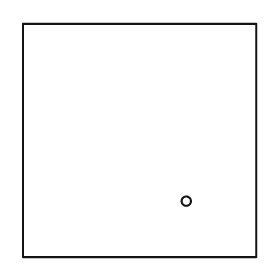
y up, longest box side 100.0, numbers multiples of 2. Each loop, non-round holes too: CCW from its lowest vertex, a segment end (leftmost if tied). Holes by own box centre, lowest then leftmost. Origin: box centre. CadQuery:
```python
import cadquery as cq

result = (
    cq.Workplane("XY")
    .moveTo(-50.0, -50.0)
    .lineTo(50.0, -50.0)
    .lineTo(50.0, 50.0)
    .lineTo(-50.0, 50.0)
    .close()
    .moveTo(20.0, -26.0)
    .circle(2.0)
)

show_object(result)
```